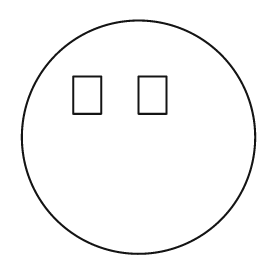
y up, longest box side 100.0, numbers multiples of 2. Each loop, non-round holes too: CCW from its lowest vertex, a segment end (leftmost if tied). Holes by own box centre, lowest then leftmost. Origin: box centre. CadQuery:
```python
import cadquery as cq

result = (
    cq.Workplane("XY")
    .moveTo(0.0, 0.0)
    .circle(50.0)
    .moveTo(-28.0, 10.0)
    .lineTo(-16.0, 10.0)
    .lineTo(-16.0, 26.0)
    .lineTo(-28.0, 26.0)
    .close()
    .moveTo(0.0, 10.0)
    .lineTo(12.0, 10.0)
    .lineTo(12.0, 26.0)
    .lineTo(0.0, 26.0)
    .close()
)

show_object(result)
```